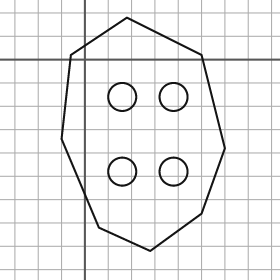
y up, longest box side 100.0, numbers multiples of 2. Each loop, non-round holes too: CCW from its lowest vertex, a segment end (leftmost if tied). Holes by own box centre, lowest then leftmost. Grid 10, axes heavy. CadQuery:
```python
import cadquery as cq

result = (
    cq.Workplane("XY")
    .moveTo(28.0, -82.0)
    .lineTo(50.0, -66.0)
    .lineTo(60.0, -38.0)
    .lineTo(50.0, 2.0)
    .lineTo(18.0, 18.0)
    .lineTo(-6.0, 2.0)
    .lineTo(-10.0, -34.0)
    .lineTo(6.0, -72.0)
    .close()
    .moveTo(16.0, -48.0)
    .circle(6.0)
    .moveTo(38.0, -48.0)
    .circle(6.0)
    .moveTo(16.0, -16.0)
    .circle(6.0)
    .moveTo(38.0, -16.0)
    .circle(6.0)
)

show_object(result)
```